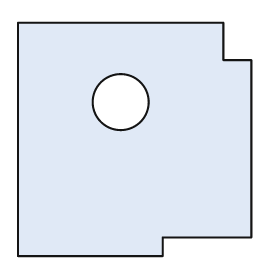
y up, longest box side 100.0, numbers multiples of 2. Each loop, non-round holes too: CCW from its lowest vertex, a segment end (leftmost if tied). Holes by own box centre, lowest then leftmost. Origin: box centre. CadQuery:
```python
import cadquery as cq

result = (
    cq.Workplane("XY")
    .moveTo(-50.0, -50.0)
    .lineTo(12.0, -50.0)
    .lineTo(12.0, -42.0)
    .lineTo(50.0, -42.0)
    .lineTo(50.0, 34.0)
    .lineTo(38.0, 34.0)
    .lineTo(38.0, 50.0)
    .lineTo(-50.0, 50.0)
    .close()
    .moveTo(-6.0, 16.0)
    .circle(12.0)
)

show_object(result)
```